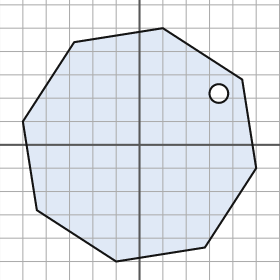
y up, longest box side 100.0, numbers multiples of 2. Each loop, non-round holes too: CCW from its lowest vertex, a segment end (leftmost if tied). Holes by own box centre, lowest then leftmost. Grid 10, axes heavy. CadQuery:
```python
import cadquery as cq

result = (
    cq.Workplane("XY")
    .moveTo(-10.0, -50.0)
    .lineTo(28.0, -44.0)
    .lineTo(50.0, -10.0)
    .lineTo(44.0, 28.0)
    .lineTo(10.0, 50.0)
    .lineTo(-28.0, 44.0)
    .lineTo(-50.0, 10.0)
    .lineTo(-44.0, -28.0)
    .close()
    .moveTo(34.0, 22.0)
    .circle(4.0)
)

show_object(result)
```